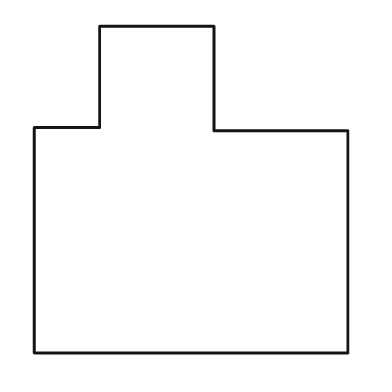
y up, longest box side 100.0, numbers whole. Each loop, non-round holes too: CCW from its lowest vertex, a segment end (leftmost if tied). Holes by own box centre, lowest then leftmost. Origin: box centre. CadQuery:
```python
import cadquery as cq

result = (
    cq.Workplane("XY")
    .moveTo(-48.0, -50.0)
    .lineTo(48.0, -50.0)
    .lineTo(48.0, 18.0)
    .lineTo(7.0, 18.0)
    .lineTo(7.0, 50.0)
    .lineTo(-28.0, 50.0)
    .lineTo(-28.0, 19.0)
    .lineTo(-48.0, 19.0)
    .close()
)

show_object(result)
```